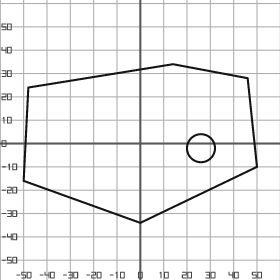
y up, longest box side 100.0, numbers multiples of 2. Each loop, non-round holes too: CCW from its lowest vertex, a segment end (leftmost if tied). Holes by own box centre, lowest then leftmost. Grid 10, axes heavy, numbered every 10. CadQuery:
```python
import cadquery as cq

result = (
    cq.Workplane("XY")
    .moveTo(0.0, -34.0)
    .lineTo(50.0, -10.0)
    .lineTo(46.0, 28.0)
    .lineTo(14.0, 34.0)
    .lineTo(-48.0, 24.0)
    .lineTo(-50.0, -16.0)
    .close()
    .moveTo(26.0, -2.0)
    .circle(6.0)
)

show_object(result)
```